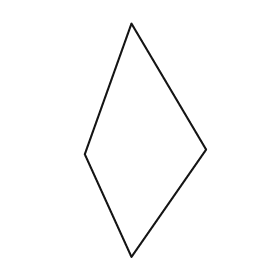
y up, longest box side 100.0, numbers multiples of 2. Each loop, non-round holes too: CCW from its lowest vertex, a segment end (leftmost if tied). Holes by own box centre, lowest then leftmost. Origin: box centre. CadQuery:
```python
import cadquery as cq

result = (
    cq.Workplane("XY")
    .moveTo(-6.0, -50.0)
    .lineTo(26.0, -4.0)
    .lineTo(-6.0, 50.0)
    .lineTo(-26.0, -6.0)
    .close()
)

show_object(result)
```